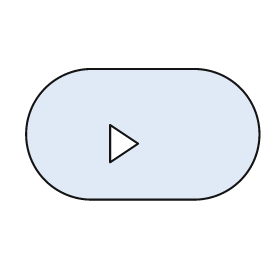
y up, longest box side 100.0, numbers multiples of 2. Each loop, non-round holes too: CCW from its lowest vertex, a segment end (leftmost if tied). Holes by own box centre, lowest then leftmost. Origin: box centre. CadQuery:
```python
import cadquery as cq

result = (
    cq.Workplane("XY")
    .moveTo(-22.0, -28.0)
    .lineTo(22.0, -28.0)
    .threePointArc((50.0, 0.0), (22.0, 28.0))
    .lineTo(-22.0, 28.0)
    .threePointArc((-50.0, 0.0), (-22.0, -28.0))
    .close()
    .moveTo(-14.0, -12.0)
    .lineTo(-2.0, -4.0)
    .lineTo(-14.0, 4.0)
    .close()
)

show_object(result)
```